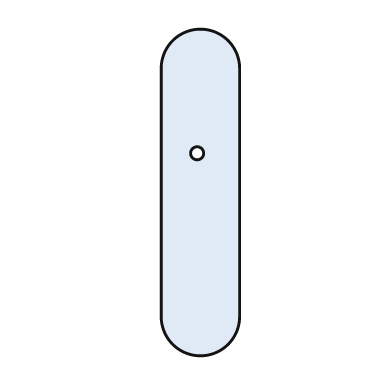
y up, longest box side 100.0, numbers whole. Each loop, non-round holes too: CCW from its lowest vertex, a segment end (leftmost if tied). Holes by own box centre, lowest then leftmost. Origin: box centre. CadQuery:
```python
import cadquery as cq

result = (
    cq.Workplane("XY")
    .moveTo(-12.0, -38.0)
    .threePointArc((0.0, -50.0), (12.0, -38.0))
    .lineTo(12.0, 38.0)
    .threePointArc((0.0, 50.0), (-12.0, 38.0))
    .close()
    .moveTo(-1.0, 12.0)
    .circle(2.0)
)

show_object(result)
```